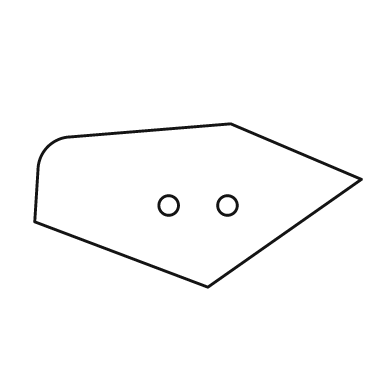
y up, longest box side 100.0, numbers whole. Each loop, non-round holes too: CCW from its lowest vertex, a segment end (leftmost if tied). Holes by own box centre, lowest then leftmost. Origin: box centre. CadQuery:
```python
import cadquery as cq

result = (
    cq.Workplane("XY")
    .moveTo(3.0, -25.0)
    .lineTo(50.0, 8.0)
    .lineTo(10.0, 25.0)
    .lineTo(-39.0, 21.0)
    .threePointArc((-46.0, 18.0), (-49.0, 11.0))
    .lineTo(-50.0, -5.0)
    .close()
    .moveTo(-9.0, 0.0)
    .circle(3.0)
    .moveTo(9.0, 0.0)
    .circle(3.0)
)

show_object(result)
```